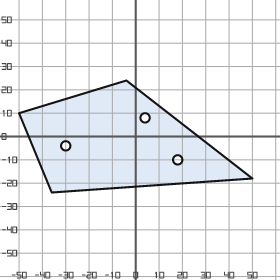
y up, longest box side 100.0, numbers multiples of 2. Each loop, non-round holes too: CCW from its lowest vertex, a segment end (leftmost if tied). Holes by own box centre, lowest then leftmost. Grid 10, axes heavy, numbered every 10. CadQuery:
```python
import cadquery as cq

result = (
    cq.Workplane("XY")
    .moveTo(-36.0, -24.0)
    .lineTo(50.0, -18.0)
    .lineTo(-4.0, 24.0)
    .lineTo(-50.0, 10.0)
    .close()
    .moveTo(18.0, -10.0)
    .circle(2.0)
    .moveTo(-30.0, -4.0)
    .circle(2.0)
    .moveTo(4.0, 8.0)
    .circle(2.0)
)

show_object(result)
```